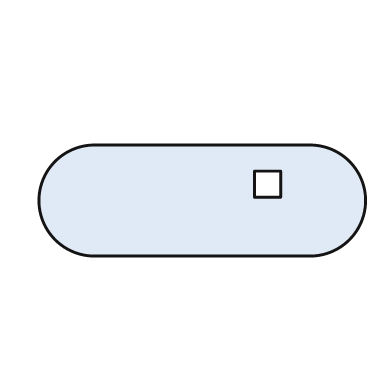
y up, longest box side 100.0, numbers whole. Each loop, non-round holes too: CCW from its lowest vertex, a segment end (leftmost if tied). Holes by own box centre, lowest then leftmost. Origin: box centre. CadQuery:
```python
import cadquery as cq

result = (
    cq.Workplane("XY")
    .moveTo(-33.0, -17.0)
    .lineTo(33.0, -17.0)
    .threePointArc((50.0, 0.0), (33.0, 17.0))
    .lineTo(-33.0, 17.0)
    .threePointArc((-50.0, 0.0), (-33.0, -17.0))
    .close()
    .moveTo(16.0, 1.0)
    .lineTo(24.0, 1.0)
    .lineTo(24.0, 9.0)
    .lineTo(16.0, 9.0)
    .close()
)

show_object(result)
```